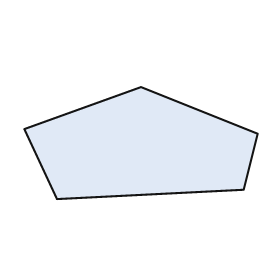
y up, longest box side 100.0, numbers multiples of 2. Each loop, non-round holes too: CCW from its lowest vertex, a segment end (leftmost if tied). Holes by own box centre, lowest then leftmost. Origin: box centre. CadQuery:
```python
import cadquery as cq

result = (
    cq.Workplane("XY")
    .moveTo(-36.0, -24.0)
    .lineTo(44.0, -20.0)
    .lineTo(50.0, 4.0)
    .lineTo(0.0, 24.0)
    .lineTo(-50.0, 6.0)
    .close()
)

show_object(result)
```